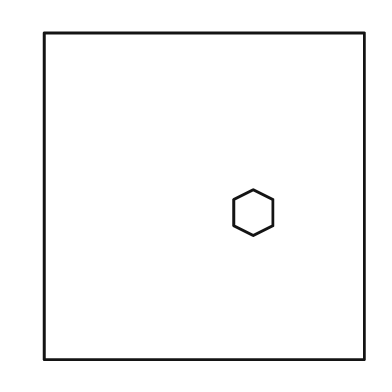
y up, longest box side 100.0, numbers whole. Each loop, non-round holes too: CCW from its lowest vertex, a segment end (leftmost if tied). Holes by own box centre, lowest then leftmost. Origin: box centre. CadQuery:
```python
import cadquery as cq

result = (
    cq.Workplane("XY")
    .moveTo(-49.0, -50.0)
    .lineTo(49.0, -50.0)
    .lineTo(49.0, 50.0)
    .lineTo(-49.0, 50.0)
    .close()
    .moveTo(15.0, -12.0)
    .lineTo(21.0, -9.0)
    .lineTo(21.0, -1.0)
    .lineTo(15.0, 2.0)
    .lineTo(9.0, -1.0)
    .lineTo(9.0, -9.0)
    .close()
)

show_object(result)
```